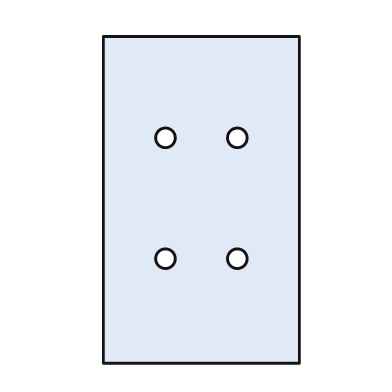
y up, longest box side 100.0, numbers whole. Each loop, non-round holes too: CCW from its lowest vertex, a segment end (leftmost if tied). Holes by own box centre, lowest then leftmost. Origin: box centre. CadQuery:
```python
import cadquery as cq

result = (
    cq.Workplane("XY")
    .moveTo(-30.0, -50.0)
    .lineTo(30.0, -50.0)
    .lineTo(30.0, 50.0)
    .lineTo(-30.0, 50.0)
    .close()
    .moveTo(-11.0, -18.0)
    .circle(3.0)
    .moveTo(11.0, -18.0)
    .circle(3.0)
    .moveTo(-11.0, 19.0)
    .circle(3.0)
    .moveTo(11.0, 19.0)
    .circle(3.0)
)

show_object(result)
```